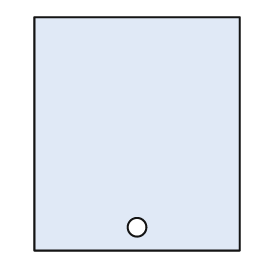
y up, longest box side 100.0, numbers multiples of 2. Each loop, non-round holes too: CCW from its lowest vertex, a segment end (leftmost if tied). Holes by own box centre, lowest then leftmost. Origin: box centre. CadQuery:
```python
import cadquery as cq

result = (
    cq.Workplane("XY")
    .moveTo(-44.0, -50.0)
    .lineTo(44.0, -50.0)
    .lineTo(44.0, 50.0)
    .lineTo(-44.0, 50.0)
    .close()
    .moveTo(0.0, -40.0)
    .circle(4.0)
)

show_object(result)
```